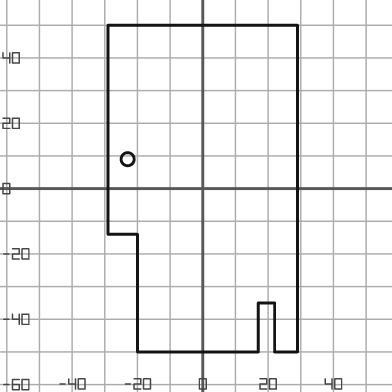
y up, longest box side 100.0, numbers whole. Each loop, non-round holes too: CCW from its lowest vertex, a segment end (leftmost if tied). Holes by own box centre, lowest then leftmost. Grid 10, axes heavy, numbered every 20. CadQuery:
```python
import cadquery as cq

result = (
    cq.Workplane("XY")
    .moveTo(-20.0, -50.0)
    .lineTo(17.0, -50.0)
    .lineTo(17.0, -35.0)
    .lineTo(22.0, -35.0)
    .lineTo(22.0, -50.0)
    .lineTo(29.0, -50.0)
    .lineTo(29.0, 50.0)
    .lineTo(-29.0, 50.0)
    .lineTo(-29.0, -14.0)
    .lineTo(-20.0, -14.0)
    .close()
    .moveTo(-23.0, 9.0)
    .circle(2.0)
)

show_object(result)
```